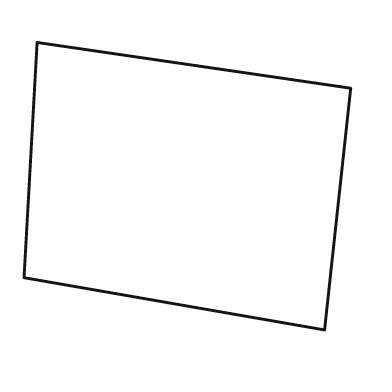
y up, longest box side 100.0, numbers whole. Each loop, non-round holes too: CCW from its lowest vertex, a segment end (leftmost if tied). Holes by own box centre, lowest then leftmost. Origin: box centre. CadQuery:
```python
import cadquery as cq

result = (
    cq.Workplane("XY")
    .moveTo(42.0, -44.0)
    .lineTo(50.0, 30.0)
    .lineTo(-46.0, 44.0)
    .lineTo(-50.0, -28.0)
    .close()
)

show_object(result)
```